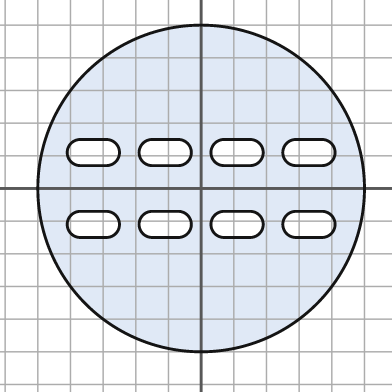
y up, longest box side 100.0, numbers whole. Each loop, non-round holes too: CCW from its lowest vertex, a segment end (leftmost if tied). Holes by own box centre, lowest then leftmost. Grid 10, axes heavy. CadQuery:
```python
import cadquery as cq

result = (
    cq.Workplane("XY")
    .moveTo(0.0, 0.0)
    .circle(50.0)
    .moveTo(-37.0, -15.0)
    .lineTo(-29.0, -15.0)
    .threePointArc((-25.0, -11.0), (-29.0, -7.0))
    .lineTo(-37.0, -7.0)
    .threePointArc((-41.0, -11.0), (-37.0, -15.0))
    .close()
    .moveTo(-15.0, -15.0)
    .lineTo(-7.0, -15.0)
    .threePointArc((-3.0, -11.0), (-7.0, -7.0))
    .lineTo(-15.0, -7.0)
    .threePointArc((-19.0, -11.0), (-15.0, -15.0))
    .close()
    .moveTo(7.0, -15.0)
    .lineTo(15.0, -15.0)
    .threePointArc((19.0, -11.0), (15.0, -7.0))
    .lineTo(7.0, -7.0)
    .threePointArc((3.0, -11.0), (7.0, -15.0))
    .close()
    .moveTo(29.0, -15.0)
    .lineTo(37.0, -15.0)
    .threePointArc((41.0, -11.0), (37.0, -7.0))
    .lineTo(29.0, -7.0)
    .threePointArc((25.0, -11.0), (29.0, -15.0))
    .close()
    .moveTo(-37.0, 7.0)
    .lineTo(-29.0, 7.0)
    .threePointArc((-25.0, 11.0), (-29.0, 15.0))
    .lineTo(-37.0, 15.0)
    .threePointArc((-41.0, 11.0), (-37.0, 7.0))
    .close()
    .moveTo(-15.0, 7.0)
    .lineTo(-7.0, 7.0)
    .threePointArc((-3.0, 11.0), (-7.0, 15.0))
    .lineTo(-15.0, 15.0)
    .threePointArc((-19.0, 11.0), (-15.0, 7.0))
    .close()
    .moveTo(7.0, 7.0)
    .lineTo(15.0, 7.0)
    .threePointArc((19.0, 11.0), (15.0, 15.0))
    .lineTo(7.0, 15.0)
    .threePointArc((3.0, 11.0), (7.0, 7.0))
    .close()
    .moveTo(29.0, 7.0)
    .lineTo(37.0, 7.0)
    .threePointArc((41.0, 11.0), (37.0, 15.0))
    .lineTo(29.0, 15.0)
    .threePointArc((25.0, 11.0), (29.0, 7.0))
    .close()
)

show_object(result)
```